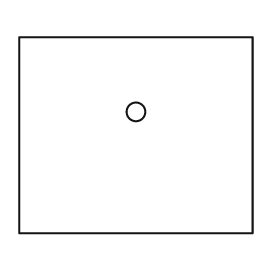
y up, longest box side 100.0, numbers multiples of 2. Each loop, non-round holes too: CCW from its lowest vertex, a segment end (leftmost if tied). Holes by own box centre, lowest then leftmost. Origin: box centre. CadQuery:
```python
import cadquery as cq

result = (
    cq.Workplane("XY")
    .moveTo(-50.0, -42.0)
    .lineTo(50.0, -42.0)
    .lineTo(50.0, 42.0)
    .lineTo(-50.0, 42.0)
    .close()
    .moveTo(0.0, 10.0)
    .circle(4.0)
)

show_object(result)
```